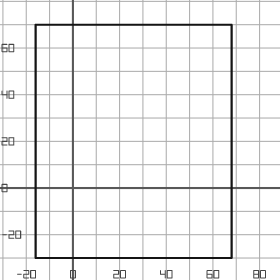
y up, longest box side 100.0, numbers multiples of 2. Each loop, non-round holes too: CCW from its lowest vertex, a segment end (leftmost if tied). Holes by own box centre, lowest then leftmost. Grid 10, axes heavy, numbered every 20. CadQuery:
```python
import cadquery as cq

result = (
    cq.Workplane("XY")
    .moveTo(-16.0, -30.0)
    .lineTo(68.0, -30.0)
    .lineTo(68.0, 70.0)
    .lineTo(-16.0, 70.0)
    .close()
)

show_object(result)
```